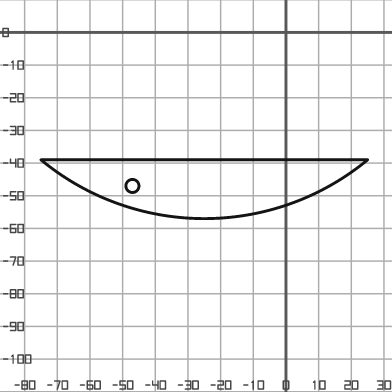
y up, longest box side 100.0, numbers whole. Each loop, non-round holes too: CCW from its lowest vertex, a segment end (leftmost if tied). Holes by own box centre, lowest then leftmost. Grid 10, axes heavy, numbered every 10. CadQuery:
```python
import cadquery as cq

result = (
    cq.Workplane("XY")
    .moveTo(-75.0, -39.0)
    .threePointArc((-25.0, -57.0), (25.0, -39.0))
    .close()
    .moveTo(-47.0, -47.0)
    .circle(2.0)
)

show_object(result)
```